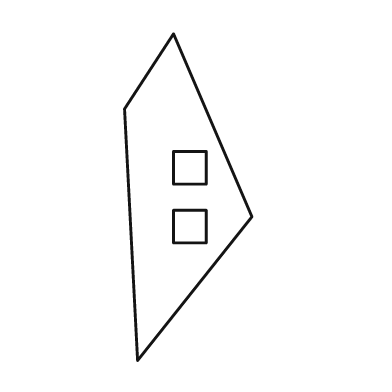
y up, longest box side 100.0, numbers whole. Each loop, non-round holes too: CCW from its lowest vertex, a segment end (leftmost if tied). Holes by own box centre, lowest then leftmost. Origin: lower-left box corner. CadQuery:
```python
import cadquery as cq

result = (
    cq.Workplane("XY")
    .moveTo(4.0, 0.0)
    .lineTo(39.0, 44.0)
    .lineTo(15.0, 100.0)
    .lineTo(0.0, 77.0)
    .close()
    .moveTo(15.0, 36.0)
    .lineTo(25.0, 36.0)
    .lineTo(25.0, 46.0)
    .lineTo(15.0, 46.0)
    .close()
    .moveTo(15.0, 54.0)
    .lineTo(25.0, 54.0)
    .lineTo(25.0, 64.0)
    .lineTo(15.0, 64.0)
    .close()
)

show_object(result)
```